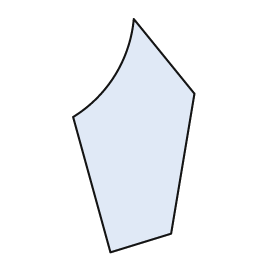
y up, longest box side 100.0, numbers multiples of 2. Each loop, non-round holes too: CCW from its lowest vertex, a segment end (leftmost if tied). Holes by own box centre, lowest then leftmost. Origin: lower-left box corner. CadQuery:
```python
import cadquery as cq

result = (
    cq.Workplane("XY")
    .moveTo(16.0, 0.0)
    .lineTo(42.0, 8.0)
    .lineTo(52.0, 68.0)
    .lineTo(26.0, 100.0)
    .threePointArc((18.0, 76.0), (0.0, 58.0))
    .close()
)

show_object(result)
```